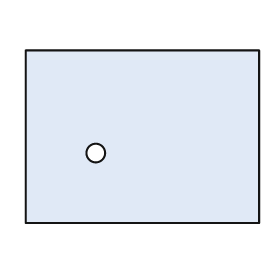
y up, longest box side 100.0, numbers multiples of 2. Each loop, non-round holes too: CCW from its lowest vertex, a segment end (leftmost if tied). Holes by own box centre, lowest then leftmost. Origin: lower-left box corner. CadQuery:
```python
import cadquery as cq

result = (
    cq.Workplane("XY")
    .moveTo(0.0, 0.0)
    .lineTo(100.0, 0.0)
    .lineTo(100.0, 74.0)
    .lineTo(0.0, 74.0)
    .close()
    .moveTo(30.0, 30.0)
    .circle(4.0)
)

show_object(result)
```